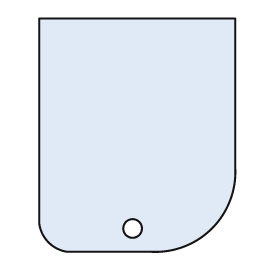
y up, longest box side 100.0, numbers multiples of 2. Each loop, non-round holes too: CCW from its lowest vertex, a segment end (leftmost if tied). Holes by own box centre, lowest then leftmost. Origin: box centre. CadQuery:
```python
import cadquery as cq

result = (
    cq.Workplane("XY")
    .moveTo(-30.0, -50.0)
    .lineTo(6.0, -50.0)
    .threePointArc((32.0, -40.0), (42.0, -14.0))
    .lineTo(42.0, 50.0)
    .lineTo(-42.0, 50.0)
    .lineTo(-42.0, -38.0)
    .threePointArc((-38.0, -46.0), (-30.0, -50.0))
    .close()
    .moveTo(-2.0, -40.0)
    .circle(4.0)
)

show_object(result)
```